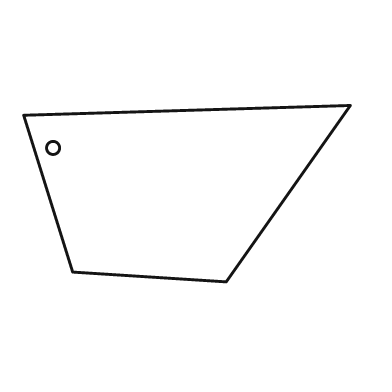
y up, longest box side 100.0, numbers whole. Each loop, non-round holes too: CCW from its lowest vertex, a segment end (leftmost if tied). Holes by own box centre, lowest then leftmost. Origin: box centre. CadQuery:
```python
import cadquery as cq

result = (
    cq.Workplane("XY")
    .moveTo(12.0, -27.0)
    .lineTo(50.0, 27.0)
    .lineTo(-50.0, 24.0)
    .lineTo(-35.0, -24.0)
    .close()
    .moveTo(-41.0, 14.0)
    .circle(2.0)
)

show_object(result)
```